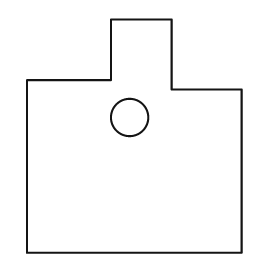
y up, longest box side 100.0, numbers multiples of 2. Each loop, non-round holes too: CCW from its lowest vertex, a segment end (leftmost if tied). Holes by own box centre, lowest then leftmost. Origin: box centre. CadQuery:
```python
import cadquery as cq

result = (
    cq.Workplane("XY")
    .moveTo(-46.0, -50.0)
    .lineTo(46.0, -50.0)
    .lineTo(46.0, 20.0)
    .lineTo(16.0, 20.0)
    .lineTo(16.0, 50.0)
    .lineTo(-10.0, 50.0)
    .lineTo(-10.0, 24.0)
    .lineTo(-46.0, 24.0)
    .close()
    .moveTo(-2.0, 8.0)
    .circle(8.0)
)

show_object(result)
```